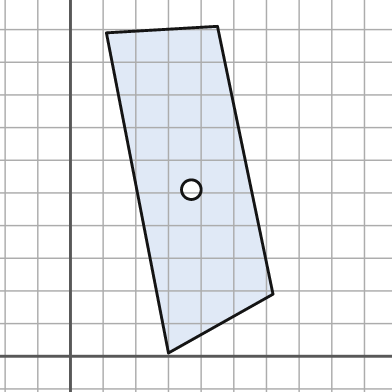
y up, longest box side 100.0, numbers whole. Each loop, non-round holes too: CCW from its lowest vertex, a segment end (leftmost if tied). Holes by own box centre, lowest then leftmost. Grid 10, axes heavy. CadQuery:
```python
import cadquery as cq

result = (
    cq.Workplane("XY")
    .moveTo(30.0, 1.0)
    .lineTo(62.0, 19.0)
    .lineTo(45.0, 101.0)
    .lineTo(11.0, 99.0)
    .close()
    .moveTo(37.0, 51.0)
    .circle(3.0)
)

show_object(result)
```